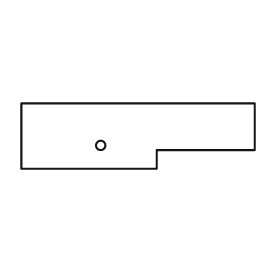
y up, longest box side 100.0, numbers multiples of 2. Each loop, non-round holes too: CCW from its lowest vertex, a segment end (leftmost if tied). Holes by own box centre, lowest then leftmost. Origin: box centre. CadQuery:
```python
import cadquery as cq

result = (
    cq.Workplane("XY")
    .moveTo(-50.0, -14.0)
    .lineTo(8.0, -14.0)
    .lineTo(8.0, -6.0)
    .lineTo(50.0, -6.0)
    .lineTo(50.0, 14.0)
    .lineTo(-50.0, 14.0)
    .close()
    .moveTo(-16.0, -4.0)
    .circle(2.0)
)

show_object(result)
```